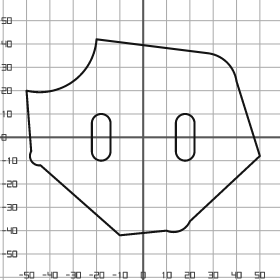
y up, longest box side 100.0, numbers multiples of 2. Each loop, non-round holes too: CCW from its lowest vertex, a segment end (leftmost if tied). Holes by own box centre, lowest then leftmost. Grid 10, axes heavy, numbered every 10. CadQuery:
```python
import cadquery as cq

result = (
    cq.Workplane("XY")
    .moveTo(-10.0, -42.0)
    .lineTo(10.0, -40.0)
    .threePointArc((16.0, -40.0), (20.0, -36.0))
    .lineTo(50.0, -8.0)
    .lineTo(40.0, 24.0)
    .threePointArc((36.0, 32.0), (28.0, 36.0))
    .lineTo(-20.0, 42.0)
    .threePointArc((-30.0, 24.0), (-50.0, 20.0))
    .lineTo(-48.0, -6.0)
    .threePointArc((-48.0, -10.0), (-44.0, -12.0))
    .close()
    .moveTo(-22.0, -6.0)
    .threePointArc((-18.0, -10.0), (-14.0, -6.0))
    .lineTo(-14.0, 6.0)
    .threePointArc((-18.0, 10.0), (-22.0, 6.0))
    .close()
    .moveTo(14.0, -6.0)
    .threePointArc((18.0, -10.0), (22.0, -6.0))
    .lineTo(22.0, 6.0)
    .threePointArc((18.0, 10.0), (14.0, 6.0))
    .close()
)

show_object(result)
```